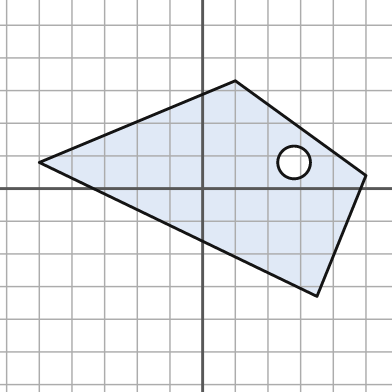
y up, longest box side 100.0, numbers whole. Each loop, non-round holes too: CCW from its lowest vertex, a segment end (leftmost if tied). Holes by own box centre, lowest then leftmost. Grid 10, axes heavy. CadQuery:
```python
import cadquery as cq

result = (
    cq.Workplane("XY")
    .moveTo(35.0, -33.0)
    .lineTo(50.0, 4.0)
    .lineTo(10.0, 33.0)
    .lineTo(-50.0, 8.0)
    .close()
    .moveTo(28.0, 8.0)
    .circle(5.0)
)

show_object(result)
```